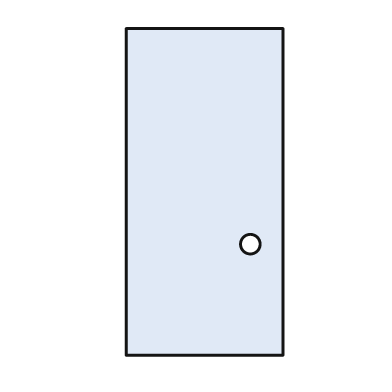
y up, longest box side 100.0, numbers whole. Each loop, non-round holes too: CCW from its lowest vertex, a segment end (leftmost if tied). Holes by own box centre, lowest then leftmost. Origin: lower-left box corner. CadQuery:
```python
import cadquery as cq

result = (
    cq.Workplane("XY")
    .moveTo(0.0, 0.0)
    .lineTo(48.0, 0.0)
    .lineTo(48.0, 100.0)
    .lineTo(0.0, 100.0)
    .close()
    .moveTo(38.0, 34.0)
    .circle(3.0)
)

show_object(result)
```